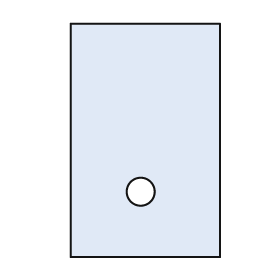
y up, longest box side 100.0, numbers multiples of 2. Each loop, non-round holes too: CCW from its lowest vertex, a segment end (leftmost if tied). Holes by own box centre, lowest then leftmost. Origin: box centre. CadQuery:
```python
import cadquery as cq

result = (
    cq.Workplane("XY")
    .moveTo(-32.0, -50.0)
    .lineTo(32.0, -50.0)
    .lineTo(32.0, 50.0)
    .lineTo(-32.0, 50.0)
    .close()
    .moveTo(-2.0, -22.0)
    .circle(6.0)
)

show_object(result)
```